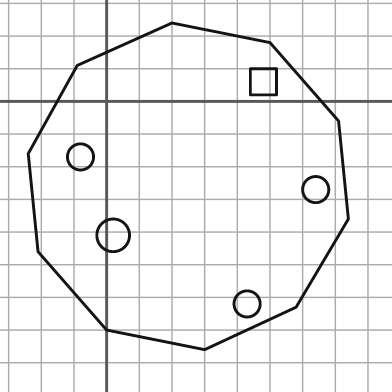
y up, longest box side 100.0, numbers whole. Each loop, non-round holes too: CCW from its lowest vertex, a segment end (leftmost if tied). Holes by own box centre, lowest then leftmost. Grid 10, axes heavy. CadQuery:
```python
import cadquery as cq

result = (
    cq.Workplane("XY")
    .moveTo(30.0, -76.0)
    .lineTo(58.0, -63.0)
    .lineTo(74.0, -36.0)
    .lineTo(71.0, -6.0)
    .lineTo(50.0, 18.0)
    .lineTo(20.0, 24.0)
    .lineTo(-9.0, 11.0)
    .lineTo(-24.0, -16.0)
    .lineTo(-21.0, -46.0)
    .lineTo(0.0, -70.0)
    .close()
    .moveTo(43.0, -62.0)
    .circle(4.0)
    .moveTo(2.0, -41.0)
    .circle(5.0)
    .moveTo(64.0, -27.0)
    .circle(4.0)
    .moveTo(-8.0, -17.0)
    .circle(4.0)
    .moveTo(44.0, 2.0)
    .lineTo(52.0, 2.0)
    .lineTo(52.0, 10.0)
    .lineTo(44.0, 10.0)
    .close()
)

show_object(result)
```